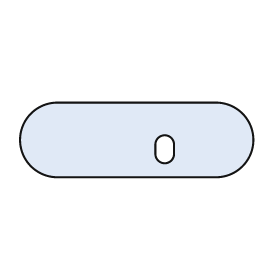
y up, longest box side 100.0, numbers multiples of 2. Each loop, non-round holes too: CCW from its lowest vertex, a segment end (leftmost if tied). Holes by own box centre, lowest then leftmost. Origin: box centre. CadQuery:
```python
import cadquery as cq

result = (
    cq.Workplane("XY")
    .moveTo(-34.0, -16.0)
    .lineTo(34.0, -16.0)
    .threePointArc((50.0, 0.0), (34.0, 16.0))
    .lineTo(-34.0, 16.0)
    .threePointArc((-50.0, 0.0), (-34.0, -16.0))
    .close()
    .moveTo(8.0, -6.0)
    .threePointArc((12.0, -10.0), (16.0, -6.0))
    .lineTo(16.0, -2.0)
    .threePointArc((12.0, 2.0), (8.0, -2.0))
    .close()
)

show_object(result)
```